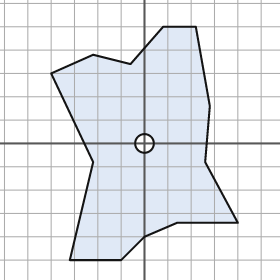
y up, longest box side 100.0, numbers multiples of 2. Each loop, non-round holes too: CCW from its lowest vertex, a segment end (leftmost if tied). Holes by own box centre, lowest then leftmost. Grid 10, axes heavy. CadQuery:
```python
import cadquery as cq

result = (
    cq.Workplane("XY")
    .moveTo(-32.0, -50.0)
    .lineTo(-10.0, -50.0)
    .lineTo(0.0, -40.0)
    .lineTo(14.0, -34.0)
    .lineTo(40.0, -34.0)
    .lineTo(26.0, -8.0)
    .lineTo(28.0, 16.0)
    .lineTo(22.0, 50.0)
    .lineTo(8.0, 50.0)
    .lineTo(-6.0, 34.0)
    .lineTo(-22.0, 38.0)
    .lineTo(-40.0, 30.0)
    .lineTo(-22.0, -8.0)
    .close()
    .moveTo(0.0, 0.0)
    .circle(4.0)
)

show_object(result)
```